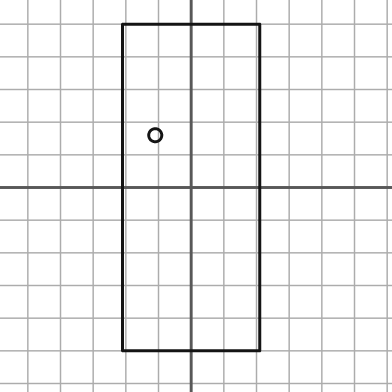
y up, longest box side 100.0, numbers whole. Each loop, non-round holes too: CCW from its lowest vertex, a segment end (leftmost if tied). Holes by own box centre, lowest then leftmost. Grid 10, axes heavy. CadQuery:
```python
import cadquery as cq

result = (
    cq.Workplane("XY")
    .moveTo(-21.0, -50.0)
    .lineTo(21.0, -50.0)
    .lineTo(21.0, 50.0)
    .lineTo(-21.0, 50.0)
    .close()
    .moveTo(-11.0, 16.0)
    .circle(2.0)
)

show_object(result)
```